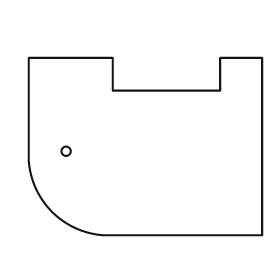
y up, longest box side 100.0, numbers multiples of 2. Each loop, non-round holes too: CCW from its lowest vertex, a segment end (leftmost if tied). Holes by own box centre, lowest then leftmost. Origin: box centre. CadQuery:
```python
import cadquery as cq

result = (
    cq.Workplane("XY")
    .moveTo(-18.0, -38.0)
    .lineTo(50.0, -38.0)
    .lineTo(50.0, 38.0)
    .lineTo(32.0, 38.0)
    .lineTo(32.0, 24.0)
    .lineTo(-14.0, 24.0)
    .lineTo(-14.0, 38.0)
    .lineTo(-50.0, 38.0)
    .lineTo(-50.0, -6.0)
    .threePointArc((-40.0, -28.0), (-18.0, -38.0))
    .close()
    .moveTo(-34.0, -2.0)
    .circle(2.0)
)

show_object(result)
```